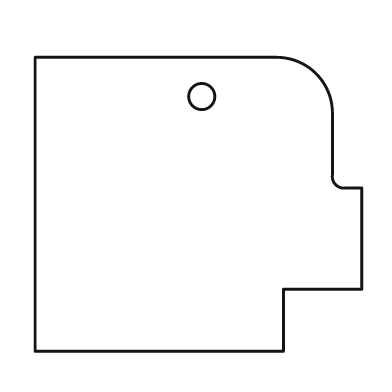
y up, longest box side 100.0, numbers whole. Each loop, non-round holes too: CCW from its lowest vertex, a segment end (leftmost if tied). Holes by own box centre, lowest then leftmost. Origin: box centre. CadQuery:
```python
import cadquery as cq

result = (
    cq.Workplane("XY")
    .moveTo(-50.0, -45.0)
    .lineTo(26.0, -45.0)
    .lineTo(26.0, -26.0)
    .lineTo(50.0, -26.0)
    .lineTo(50.0, 5.0)
    .lineTo(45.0, 5.0)
    .threePointArc((42.0, 6.0), (41.0, 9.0))
    .lineTo(41.0, 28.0)
    .threePointArc((36.0, 40.0), (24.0, 45.0))
    .lineTo(-50.0, 45.0)
    .close()
    .moveTo(1.0, 33.0)
    .circle(4.0)
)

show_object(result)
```